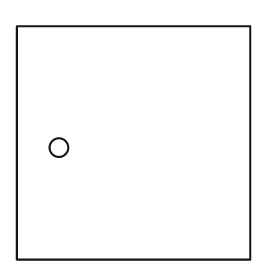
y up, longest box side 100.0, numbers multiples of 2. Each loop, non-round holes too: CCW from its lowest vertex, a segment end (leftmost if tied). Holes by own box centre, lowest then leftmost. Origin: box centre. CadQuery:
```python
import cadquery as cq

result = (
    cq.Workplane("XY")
    .moveTo(-50.0, -50.0)
    .lineTo(50.0, -50.0)
    .lineTo(50.0, 50.0)
    .lineTo(-50.0, 50.0)
    .close()
    .moveTo(-32.0, -2.0)
    .circle(4.0)
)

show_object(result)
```